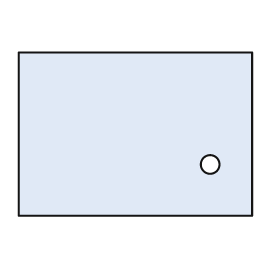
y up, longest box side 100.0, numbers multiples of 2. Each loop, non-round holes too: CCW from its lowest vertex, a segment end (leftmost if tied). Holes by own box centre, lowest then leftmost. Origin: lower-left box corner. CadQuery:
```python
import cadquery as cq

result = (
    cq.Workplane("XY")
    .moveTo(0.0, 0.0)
    .lineTo(100.0, 0.0)
    .lineTo(100.0, 70.0)
    .lineTo(0.0, 70.0)
    .close()
    .moveTo(82.0, 22.0)
    .circle(4.0)
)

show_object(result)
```